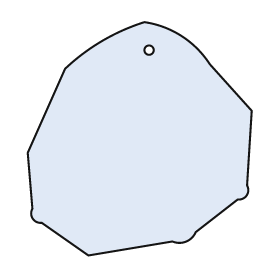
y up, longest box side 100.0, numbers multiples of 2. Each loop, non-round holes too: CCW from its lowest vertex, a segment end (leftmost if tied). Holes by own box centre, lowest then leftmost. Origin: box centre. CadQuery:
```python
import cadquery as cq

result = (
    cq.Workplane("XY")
    .moveTo(-22.0, -50.0)
    .lineTo(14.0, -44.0)
    .threePointArc((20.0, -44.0), (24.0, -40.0))
    .lineTo(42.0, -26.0)
    .threePointArc((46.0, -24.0), (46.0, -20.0))
    .lineTo(48.0, 12.0)
    .lineTo(30.0, 32.0)
    .threePointArc((18.0, 44.0), (2.0, 50.0))
    .threePointArc((-16.0, 42.0), (-32.0, 30.0))
    .lineTo(-48.0, -6.0)
    .lineTo(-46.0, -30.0)
    .threePointArc((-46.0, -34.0), (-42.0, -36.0))
    .close()
    .moveTo(4.0, 38.0)
    .circle(2.0)
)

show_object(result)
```